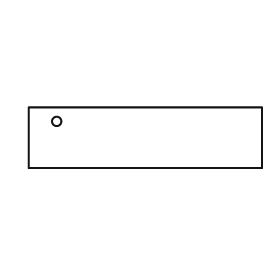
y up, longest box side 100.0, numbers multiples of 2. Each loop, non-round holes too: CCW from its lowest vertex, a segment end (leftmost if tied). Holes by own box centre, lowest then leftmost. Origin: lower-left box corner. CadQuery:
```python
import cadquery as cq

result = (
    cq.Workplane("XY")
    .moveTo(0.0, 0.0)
    .lineTo(100.0, 0.0)
    .lineTo(100.0, 26.0)
    .lineTo(0.0, 26.0)
    .close()
    .moveTo(12.0, 20.0)
    .circle(2.0)
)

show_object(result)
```